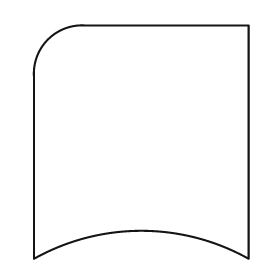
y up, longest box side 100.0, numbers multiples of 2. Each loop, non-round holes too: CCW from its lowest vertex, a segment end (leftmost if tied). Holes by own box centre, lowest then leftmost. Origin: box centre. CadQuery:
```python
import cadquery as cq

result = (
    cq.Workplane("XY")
    .moveTo(-46.0, -50.0)
    .threePointArc((0.0, -38.0), (46.0, -50.0))
    .lineTo(46.0, 50.0)
    .lineTo(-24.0, 50.0)
    .threePointArc((-40.0, 44.0), (-46.0, 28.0))
    .close()
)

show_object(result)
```